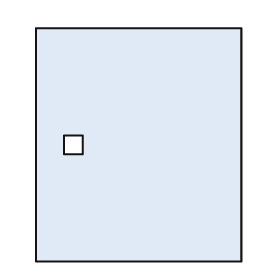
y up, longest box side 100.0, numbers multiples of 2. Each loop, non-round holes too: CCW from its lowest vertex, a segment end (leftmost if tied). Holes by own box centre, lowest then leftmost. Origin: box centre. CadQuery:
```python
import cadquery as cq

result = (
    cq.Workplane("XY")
    .moveTo(-44.0, -50.0)
    .lineTo(44.0, -50.0)
    .lineTo(44.0, 50.0)
    .lineTo(-44.0, 50.0)
    .close()
    .moveTo(-32.0, -4.0)
    .lineTo(-24.0, -4.0)
    .lineTo(-24.0, 4.0)
    .lineTo(-32.0, 4.0)
    .close()
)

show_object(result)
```